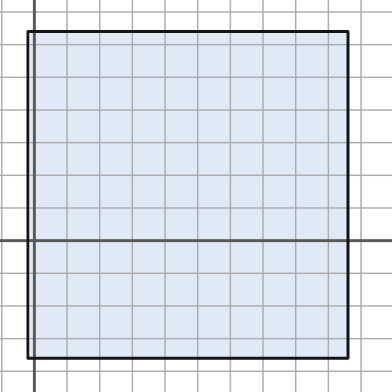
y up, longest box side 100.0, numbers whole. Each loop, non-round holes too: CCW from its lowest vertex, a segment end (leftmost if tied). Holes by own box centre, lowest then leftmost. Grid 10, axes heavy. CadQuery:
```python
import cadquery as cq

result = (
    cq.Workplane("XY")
    .moveTo(-2.0, -36.0)
    .lineTo(96.0, -36.0)
    .lineTo(96.0, 64.0)
    .lineTo(-2.0, 64.0)
    .close()
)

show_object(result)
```